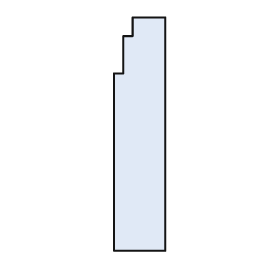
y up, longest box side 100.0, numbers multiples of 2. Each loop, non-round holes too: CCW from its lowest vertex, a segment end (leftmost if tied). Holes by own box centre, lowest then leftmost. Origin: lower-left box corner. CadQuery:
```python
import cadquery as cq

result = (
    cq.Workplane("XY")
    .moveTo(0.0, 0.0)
    .lineTo(22.0, 0.0)
    .lineTo(22.0, 100.0)
    .lineTo(8.0, 100.0)
    .lineTo(8.0, 92.0)
    .lineTo(4.0, 92.0)
    .lineTo(4.0, 76.0)
    .lineTo(0.0, 76.0)
    .close()
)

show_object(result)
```